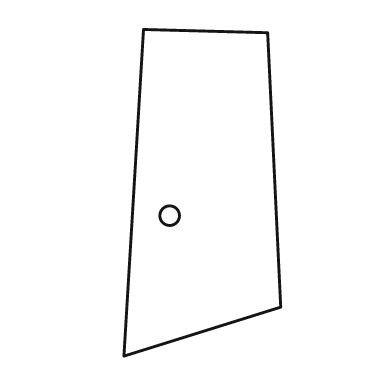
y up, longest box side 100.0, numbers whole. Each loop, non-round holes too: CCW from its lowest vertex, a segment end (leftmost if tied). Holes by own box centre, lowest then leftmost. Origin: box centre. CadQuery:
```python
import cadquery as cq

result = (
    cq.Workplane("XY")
    .moveTo(-24.0, -50.0)
    .lineTo(24.0, -35.0)
    .lineTo(20.0, 49.0)
    .lineTo(-18.0, 50.0)
    .close()
    .moveTo(-10.0, -7.0)
    .circle(3.0)
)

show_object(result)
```